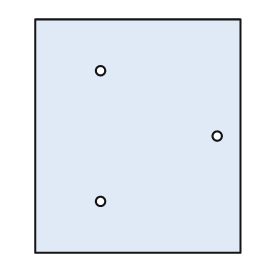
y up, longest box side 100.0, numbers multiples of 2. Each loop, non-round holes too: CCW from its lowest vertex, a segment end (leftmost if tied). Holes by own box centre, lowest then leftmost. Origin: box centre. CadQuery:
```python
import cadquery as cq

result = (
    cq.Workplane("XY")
    .moveTo(-44.0, -50.0)
    .lineTo(44.0, -50.0)
    .lineTo(44.0, 50.0)
    .lineTo(-44.0, 50.0)
    .close()
    .moveTo(-16.0, -28.0)
    .circle(2.0)
    .moveTo(34.0, 0.0)
    .circle(2.0)
    .moveTo(-16.0, 28.0)
    .circle(2.0)
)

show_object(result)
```